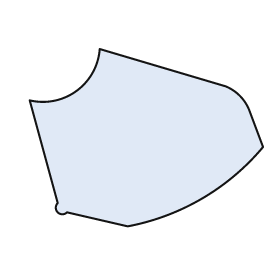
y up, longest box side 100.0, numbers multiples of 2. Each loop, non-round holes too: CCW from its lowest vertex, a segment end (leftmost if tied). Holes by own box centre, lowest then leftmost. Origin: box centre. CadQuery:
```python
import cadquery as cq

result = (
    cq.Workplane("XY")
    .moveTo(-8.0, -38.0)
    .threePointArc((24.0, -26.0), (50.0, -4.0))
    .lineTo(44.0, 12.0)
    .threePointArc((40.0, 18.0), (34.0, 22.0))
    .lineTo(-20.0, 38.0)
    .threePointArc((-30.0, 20.0), (-50.0, 16.0))
    .lineTo(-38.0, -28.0)
    .threePointArc((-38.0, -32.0), (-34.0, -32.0))
    .close()
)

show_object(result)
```